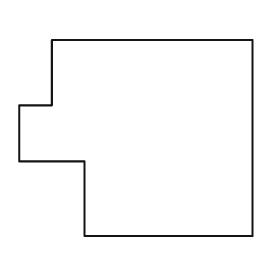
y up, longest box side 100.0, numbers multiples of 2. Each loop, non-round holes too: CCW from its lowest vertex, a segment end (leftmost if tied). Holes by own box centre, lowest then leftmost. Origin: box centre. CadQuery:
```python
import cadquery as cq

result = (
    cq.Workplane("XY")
    .moveTo(-22.0, -42.0)
    .lineTo(50.0, -42.0)
    .lineTo(50.0, 42.0)
    .lineTo(-36.0, 42.0)
    .lineTo(-36.0, 14.0)
    .lineTo(-50.0, 14.0)
    .lineTo(-50.0, -10.0)
    .lineTo(-22.0, -10.0)
    .close()
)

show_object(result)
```